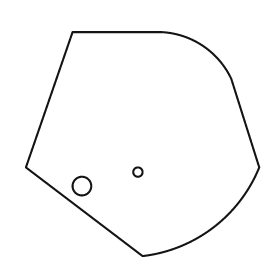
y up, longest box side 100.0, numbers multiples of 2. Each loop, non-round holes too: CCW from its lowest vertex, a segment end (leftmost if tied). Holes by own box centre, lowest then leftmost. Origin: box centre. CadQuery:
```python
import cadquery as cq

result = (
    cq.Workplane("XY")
    .moveTo(0.0, -48.0)
    .threePointArc((30.0, -36.0), (50.0, -10.0))
    .lineTo(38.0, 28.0)
    .threePointArc((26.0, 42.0), (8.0, 48.0))
    .lineTo(-30.0, 48.0)
    .lineTo(-50.0, -10.0)
    .close()
    .moveTo(-26.0, -18.0)
    .circle(4.0)
    .moveTo(-2.0, -12.0)
    .circle(2.0)
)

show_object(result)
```